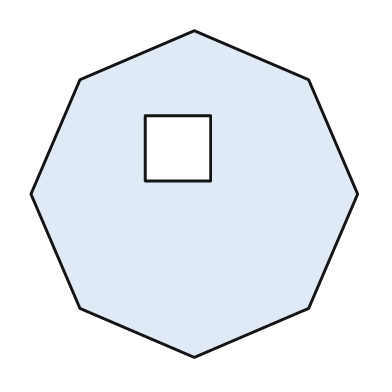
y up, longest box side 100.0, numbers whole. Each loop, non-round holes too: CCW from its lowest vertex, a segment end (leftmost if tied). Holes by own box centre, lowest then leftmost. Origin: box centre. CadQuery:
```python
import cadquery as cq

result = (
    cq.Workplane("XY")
    .moveTo(0.0, -50.0)
    .lineTo(35.0, -35.0)
    .lineTo(50.0, 0.0)
    .lineTo(35.0, 35.0)
    .lineTo(0.0, 50.0)
    .lineTo(-35.0, 35.0)
    .lineTo(-50.0, 0.0)
    .lineTo(-35.0, -35.0)
    .close()
    .moveTo(-15.0, 4.0)
    .lineTo(5.0, 4.0)
    .lineTo(5.0, 24.0)
    .lineTo(-15.0, 24.0)
    .close()
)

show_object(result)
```